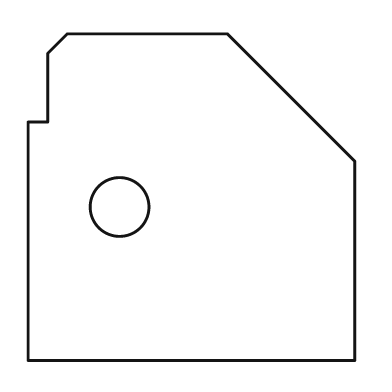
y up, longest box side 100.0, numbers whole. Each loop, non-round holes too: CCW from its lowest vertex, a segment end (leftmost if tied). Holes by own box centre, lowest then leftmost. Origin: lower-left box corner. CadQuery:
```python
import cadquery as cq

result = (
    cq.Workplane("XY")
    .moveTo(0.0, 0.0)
    .lineTo(100.0, 0.0)
    .lineTo(100.0, 61.0)
    .lineTo(61.0, 100.0)
    .lineTo(12.0, 100.0)
    .lineTo(6.0, 94.0)
    .lineTo(6.0, 73.0)
    .lineTo(0.0, 73.0)
    .close()
    .moveTo(28.0, 47.0)
    .circle(9.0)
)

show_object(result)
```